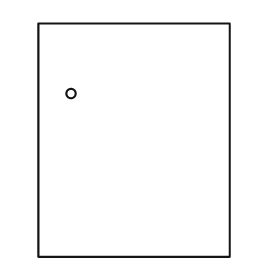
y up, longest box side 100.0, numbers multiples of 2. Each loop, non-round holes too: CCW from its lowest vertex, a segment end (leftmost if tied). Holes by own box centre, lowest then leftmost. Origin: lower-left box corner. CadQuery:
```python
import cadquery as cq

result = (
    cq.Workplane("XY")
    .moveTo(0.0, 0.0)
    .lineTo(82.0, 0.0)
    .lineTo(82.0, 100.0)
    .lineTo(0.0, 100.0)
    .close()
    .moveTo(14.0, 70.0)
    .circle(2.0)
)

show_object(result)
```